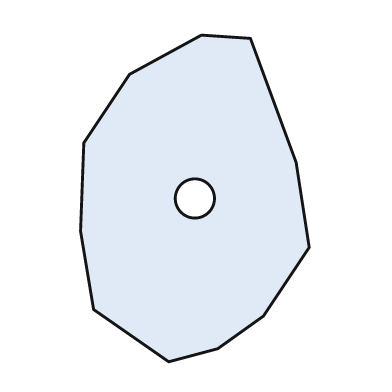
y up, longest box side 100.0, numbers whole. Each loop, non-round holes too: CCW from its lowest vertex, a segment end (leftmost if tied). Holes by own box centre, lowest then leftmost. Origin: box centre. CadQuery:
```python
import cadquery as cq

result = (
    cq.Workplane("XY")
    .moveTo(-8.0, -50.0)
    .lineTo(7.0, -46.0)
    .lineTo(21.0, -36.0)
    .lineTo(35.0, -15.0)
    .lineTo(31.0, 11.0)
    .lineTo(17.0, 49.0)
    .lineTo(2.0, 50.0)
    .lineTo(-20.0, 38.0)
    .lineTo(-34.0, 17.0)
    .lineTo(-35.0, -10.0)
    .lineTo(-31.0, -34.0)
    .close()
    .moveTo(0.0, 0.0)
    .circle(6.0)
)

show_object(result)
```